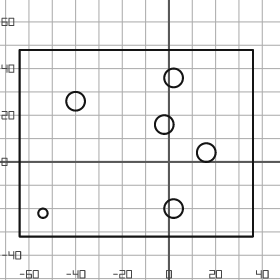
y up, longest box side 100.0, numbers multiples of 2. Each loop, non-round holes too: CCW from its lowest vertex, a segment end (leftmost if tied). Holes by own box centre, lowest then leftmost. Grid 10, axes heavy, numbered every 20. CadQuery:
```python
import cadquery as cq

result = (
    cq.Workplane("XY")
    .moveTo(-64.0, -32.0)
    .lineTo(36.0, -32.0)
    .lineTo(36.0, 48.0)
    .lineTo(-64.0, 48.0)
    .close()
    .moveTo(-54.0, -22.0)
    .circle(2.0)
    .moveTo(2.0, -20.0)
    .circle(4.0)
    .moveTo(16.0, 4.0)
    .circle(4.0)
    .moveTo(-2.0, 16.0)
    .circle(4.0)
    .moveTo(-40.0, 26.0)
    .circle(4.0)
    .moveTo(2.0, 36.0)
    .circle(4.0)
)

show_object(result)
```